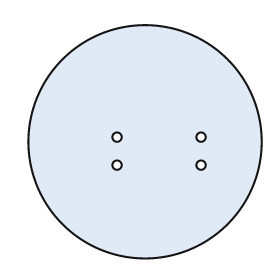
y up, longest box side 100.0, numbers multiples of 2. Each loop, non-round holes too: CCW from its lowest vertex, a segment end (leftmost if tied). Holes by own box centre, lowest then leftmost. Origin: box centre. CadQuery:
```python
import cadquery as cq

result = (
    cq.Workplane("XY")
    .moveTo(0.0, 0.0)
    .circle(50.0)
    .moveTo(-12.0, -10.0)
    .circle(2.0)
    .moveTo(24.0, -10.0)
    .circle(2.0)
    .moveTo(-12.0, 2.0)
    .circle(2.0)
    .moveTo(24.0, 2.0)
    .circle(2.0)
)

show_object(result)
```